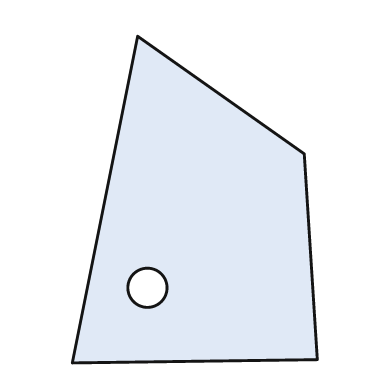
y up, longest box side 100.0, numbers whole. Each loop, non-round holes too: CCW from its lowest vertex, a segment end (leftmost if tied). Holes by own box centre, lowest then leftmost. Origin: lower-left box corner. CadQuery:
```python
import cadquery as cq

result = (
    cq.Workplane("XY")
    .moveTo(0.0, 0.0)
    .lineTo(75.0, 1.0)
    .lineTo(71.0, 64.0)
    .lineTo(20.0, 100.0)
    .close()
    .moveTo(23.0, 23.0)
    .circle(6.0)
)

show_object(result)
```